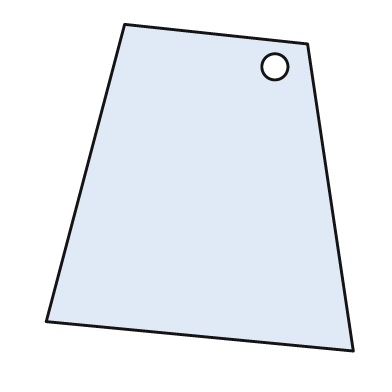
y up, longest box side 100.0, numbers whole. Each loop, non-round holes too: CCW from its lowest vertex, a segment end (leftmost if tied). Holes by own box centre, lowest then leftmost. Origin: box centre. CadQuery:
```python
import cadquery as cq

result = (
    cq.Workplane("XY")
    .moveTo(47.0, -50.0)
    .lineTo(33.0, 44.0)
    .lineTo(-23.0, 50.0)
    .lineTo(-47.0, -41.0)
    .close()
    .moveTo(23.0, 37.0)
    .circle(4.0)
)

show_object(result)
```